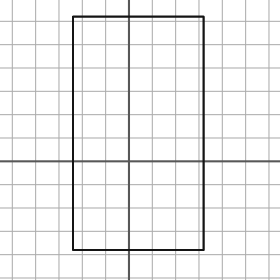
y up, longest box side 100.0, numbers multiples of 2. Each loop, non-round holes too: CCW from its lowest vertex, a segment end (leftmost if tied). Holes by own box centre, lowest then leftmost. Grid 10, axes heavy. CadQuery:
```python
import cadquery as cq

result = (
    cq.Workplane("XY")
    .moveTo(-24.0, -38.0)
    .lineTo(32.0, -38.0)
    .lineTo(32.0, 62.0)
    .lineTo(-24.0, 62.0)
    .close()
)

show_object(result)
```